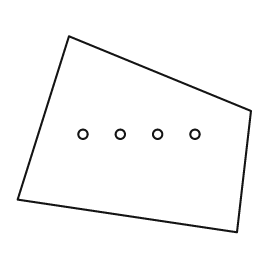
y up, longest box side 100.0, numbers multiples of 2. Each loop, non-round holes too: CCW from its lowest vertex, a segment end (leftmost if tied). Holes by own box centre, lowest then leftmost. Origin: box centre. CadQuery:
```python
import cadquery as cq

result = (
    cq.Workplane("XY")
    .moveTo(44.0, -42.0)
    .lineTo(50.0, 10.0)
    .lineTo(-28.0, 42.0)
    .lineTo(-50.0, -28.0)
    .close()
    .moveTo(-22.0, 0.0)
    .circle(2.0)
    .moveTo(-6.0, 0.0)
    .circle(2.0)
    .moveTo(10.0, 0.0)
    .circle(2.0)
    .moveTo(26.0, 0.0)
    .circle(2.0)
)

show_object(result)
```